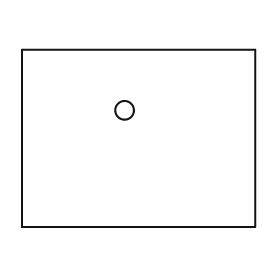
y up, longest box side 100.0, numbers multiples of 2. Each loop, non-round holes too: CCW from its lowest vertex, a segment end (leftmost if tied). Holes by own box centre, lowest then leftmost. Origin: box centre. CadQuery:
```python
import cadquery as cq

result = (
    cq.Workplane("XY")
    .moveTo(-50.0, -38.0)
    .lineTo(50.0, -38.0)
    .lineTo(50.0, 38.0)
    .lineTo(-50.0, 38.0)
    .close()
    .moveTo(-6.0, 12.0)
    .circle(4.0)
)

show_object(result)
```